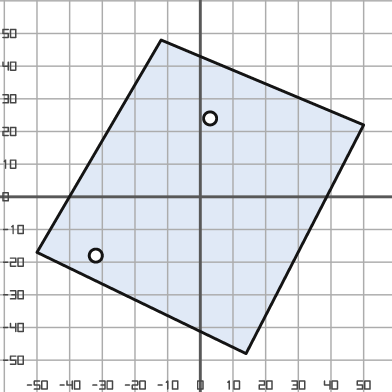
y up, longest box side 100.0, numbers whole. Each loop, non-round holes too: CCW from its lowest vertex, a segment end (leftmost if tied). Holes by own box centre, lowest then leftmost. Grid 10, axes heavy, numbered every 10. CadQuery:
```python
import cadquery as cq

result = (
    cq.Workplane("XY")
    .moveTo(14.0, -48.0)
    .lineTo(50.0, 22.0)
    .lineTo(-12.0, 48.0)
    .lineTo(-50.0, -17.0)
    .close()
    .moveTo(-32.0, -18.0)
    .circle(2.0)
    .moveTo(3.0, 24.0)
    .circle(2.0)
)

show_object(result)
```